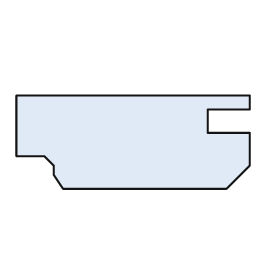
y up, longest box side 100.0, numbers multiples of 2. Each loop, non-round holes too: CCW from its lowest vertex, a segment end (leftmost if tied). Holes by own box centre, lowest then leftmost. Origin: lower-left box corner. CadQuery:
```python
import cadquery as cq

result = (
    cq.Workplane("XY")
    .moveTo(20.0, 0.0)
    .lineTo(90.0, 0.0)
    .lineTo(100.0, 10.0)
    .lineTo(100.0, 24.0)
    .lineTo(82.0, 24.0)
    .lineTo(82.0, 34.0)
    .lineTo(100.0, 34.0)
    .lineTo(100.0, 40.0)
    .lineTo(0.0, 40.0)
    .lineTo(0.0, 14.0)
    .lineTo(12.0, 14.0)
    .lineTo(16.0, 10.0)
    .lineTo(16.0, 6.0)
    .close()
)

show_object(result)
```